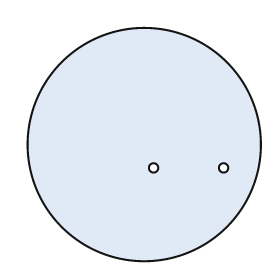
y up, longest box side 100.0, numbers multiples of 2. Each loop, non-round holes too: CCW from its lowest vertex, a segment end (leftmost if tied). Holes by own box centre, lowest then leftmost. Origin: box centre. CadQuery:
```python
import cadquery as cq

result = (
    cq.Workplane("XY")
    .moveTo(0.0, 0.0)
    .circle(50.0)
    .moveTo(4.0, -10.0)
    .circle(2.0)
    .moveTo(34.0, -10.0)
    .circle(2.0)
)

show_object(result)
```